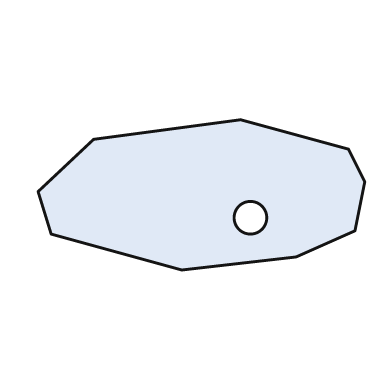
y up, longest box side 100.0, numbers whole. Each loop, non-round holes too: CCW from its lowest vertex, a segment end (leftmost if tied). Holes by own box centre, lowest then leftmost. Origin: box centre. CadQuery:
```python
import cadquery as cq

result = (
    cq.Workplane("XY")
    .moveTo(-6.0, -23.0)
    .lineTo(29.0, -19.0)
    .lineTo(47.0, -11.0)
    .lineTo(50.0, 4.0)
    .lineTo(45.0, 14.0)
    .lineTo(12.0, 23.0)
    .lineTo(-33.0, 17.0)
    .lineTo(-50.0, 1.0)
    .lineTo(-46.0, -12.0)
    .close()
    .moveTo(15.0, -7.0)
    .circle(5.0)
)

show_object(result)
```